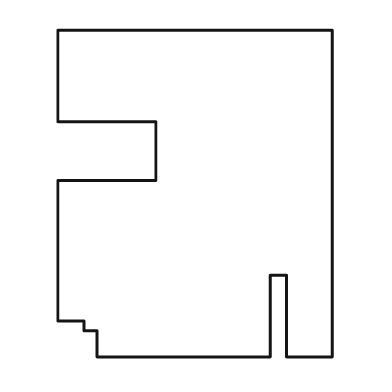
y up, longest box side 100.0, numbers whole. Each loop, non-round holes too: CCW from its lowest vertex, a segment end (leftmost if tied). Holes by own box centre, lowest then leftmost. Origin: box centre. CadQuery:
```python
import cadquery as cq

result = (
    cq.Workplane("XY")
    .moveTo(-30.0, -50.0)
    .lineTo(23.0, -50.0)
    .lineTo(23.0, -25.0)
    .lineTo(28.0, -25.0)
    .lineTo(28.0, -50.0)
    .lineTo(42.0, -50.0)
    .lineTo(42.0, 50.0)
    .lineTo(-42.0, 50.0)
    .lineTo(-42.0, 22.0)
    .lineTo(-12.0, 22.0)
    .lineTo(-12.0, 4.0)
    .lineTo(-42.0, 4.0)
    .lineTo(-42.0, -39.0)
    .lineTo(-34.0, -39.0)
    .lineTo(-34.0, -42.0)
    .lineTo(-30.0, -42.0)
    .close()
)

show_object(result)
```